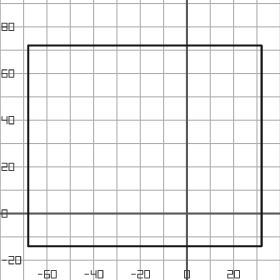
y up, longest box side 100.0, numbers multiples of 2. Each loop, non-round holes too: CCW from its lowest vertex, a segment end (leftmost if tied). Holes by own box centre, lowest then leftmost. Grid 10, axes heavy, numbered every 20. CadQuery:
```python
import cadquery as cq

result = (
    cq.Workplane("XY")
    .moveTo(-68.0, -14.0)
    .lineTo(32.0, -14.0)
    .lineTo(32.0, 72.0)
    .lineTo(-68.0, 72.0)
    .close()
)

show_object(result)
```